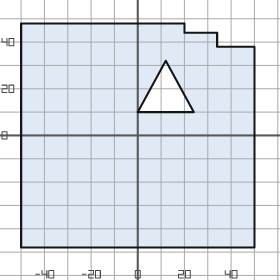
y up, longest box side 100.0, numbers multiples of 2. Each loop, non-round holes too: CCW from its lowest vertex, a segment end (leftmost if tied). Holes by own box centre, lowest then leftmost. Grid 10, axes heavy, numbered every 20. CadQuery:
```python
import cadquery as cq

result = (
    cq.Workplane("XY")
    .moveTo(-50.0, -48.0)
    .lineTo(50.0, -48.0)
    .lineTo(50.0, 38.0)
    .lineTo(34.0, 38.0)
    .lineTo(34.0, 44.0)
    .lineTo(20.0, 44.0)
    .lineTo(20.0, 48.0)
    .lineTo(-50.0, 48.0)
    .close()
    .moveTo(0.0, 10.0)
    .lineTo(24.0, 10.0)
    .lineTo(12.0, 32.0)
    .close()
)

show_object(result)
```